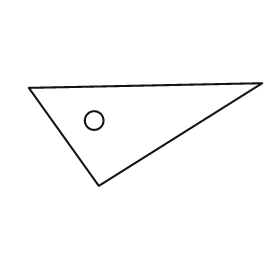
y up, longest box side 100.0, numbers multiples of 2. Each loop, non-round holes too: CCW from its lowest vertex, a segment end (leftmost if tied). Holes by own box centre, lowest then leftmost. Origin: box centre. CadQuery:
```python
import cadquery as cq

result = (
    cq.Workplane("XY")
    .moveTo(-20.0, -22.0)
    .lineTo(50.0, 22.0)
    .lineTo(-50.0, 20.0)
    .close()
    .moveTo(-22.0, 6.0)
    .circle(4.0)
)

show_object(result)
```